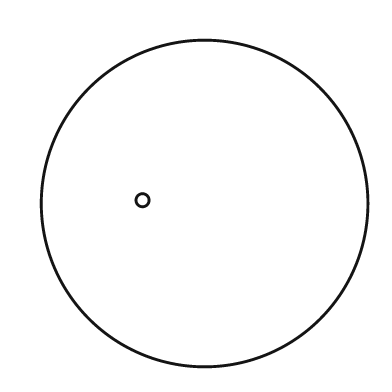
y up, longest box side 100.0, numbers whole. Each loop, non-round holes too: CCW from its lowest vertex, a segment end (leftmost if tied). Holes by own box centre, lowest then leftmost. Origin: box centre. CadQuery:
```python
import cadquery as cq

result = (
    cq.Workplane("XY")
    .moveTo(0.0, 0.0)
    .circle(50.0)
    .moveTo(-19.0, 1.0)
    .circle(2.0)
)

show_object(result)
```